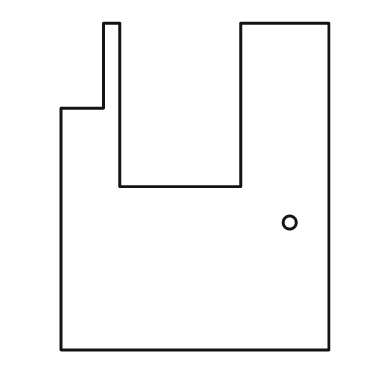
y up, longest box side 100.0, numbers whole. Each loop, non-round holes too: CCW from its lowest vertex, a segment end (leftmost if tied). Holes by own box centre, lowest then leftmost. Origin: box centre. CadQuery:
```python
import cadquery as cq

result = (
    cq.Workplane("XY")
    .moveTo(-41.0, -50.0)
    .lineTo(41.0, -50.0)
    .lineTo(41.0, 50.0)
    .lineTo(14.0, 50.0)
    .lineTo(14.0, 0.0)
    .lineTo(-23.0, 0.0)
    .lineTo(-23.0, 50.0)
    .lineTo(-28.0, 50.0)
    .lineTo(-28.0, 24.0)
    .lineTo(-41.0, 24.0)
    .close()
    .moveTo(29.0, -11.0)
    .circle(2.0)
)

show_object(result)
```